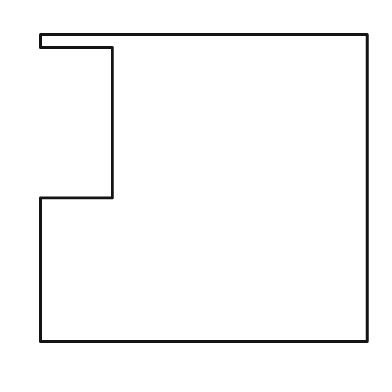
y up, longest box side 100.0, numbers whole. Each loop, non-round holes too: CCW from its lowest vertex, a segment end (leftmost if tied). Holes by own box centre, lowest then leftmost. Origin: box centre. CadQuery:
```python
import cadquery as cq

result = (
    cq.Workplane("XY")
    .moveTo(-50.0, -47.0)
    .lineTo(50.0, -47.0)
    .lineTo(50.0, 47.0)
    .lineTo(-50.0, 47.0)
    .lineTo(-50.0, 43.0)
    .lineTo(-28.0, 43.0)
    .lineTo(-28.0, -3.0)
    .lineTo(-50.0, -3.0)
    .close()
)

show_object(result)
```